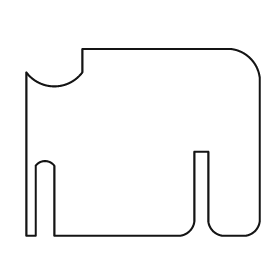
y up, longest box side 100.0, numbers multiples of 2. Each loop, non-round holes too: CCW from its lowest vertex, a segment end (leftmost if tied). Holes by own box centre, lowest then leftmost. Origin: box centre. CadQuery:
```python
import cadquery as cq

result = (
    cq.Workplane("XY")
    .moveTo(-50.0, -40.0)
    .lineTo(-46.0, -40.0)
    .lineTo(-46.0, -10.0)
    .threePointArc((-42.0, -8.0), (-38.0, -10.0))
    .lineTo(-38.0, -40.0)
    .lineTo(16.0, -40.0)
    .threePointArc((20.0, -38.0), (22.0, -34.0))
    .lineTo(22.0, -4.0)
    .lineTo(28.0, -4.0)
    .lineTo(28.0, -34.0)
    .threePointArc((30.0, -38.0), (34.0, -40.0))
    .lineTo(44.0, -40.0)
    .threePointArc((48.0, -38.0), (50.0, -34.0))
    .lineTo(50.0, 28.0)
    .threePointArc((46.0, 36.0), (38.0, 40.0))
    .lineTo(-26.0, 40.0)
    .lineTo(-26.0, 30.0)
    .threePointArc((-38.0, 24.0), (-50.0, 30.0))
    .close()
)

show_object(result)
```